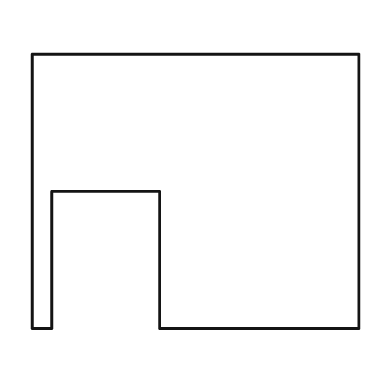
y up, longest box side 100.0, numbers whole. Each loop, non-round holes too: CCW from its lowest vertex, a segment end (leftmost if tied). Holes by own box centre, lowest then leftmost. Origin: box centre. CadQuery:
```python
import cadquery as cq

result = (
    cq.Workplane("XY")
    .moveTo(-50.0, -42.0)
    .lineTo(-44.0, -42.0)
    .lineTo(-44.0, 0.0)
    .lineTo(-11.0, 0.0)
    .lineTo(-11.0, -42.0)
    .lineTo(50.0, -42.0)
    .lineTo(50.0, 42.0)
    .lineTo(-50.0, 42.0)
    .close()
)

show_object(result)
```